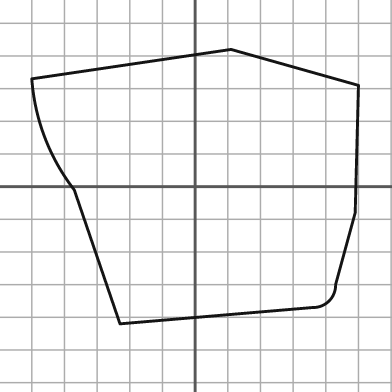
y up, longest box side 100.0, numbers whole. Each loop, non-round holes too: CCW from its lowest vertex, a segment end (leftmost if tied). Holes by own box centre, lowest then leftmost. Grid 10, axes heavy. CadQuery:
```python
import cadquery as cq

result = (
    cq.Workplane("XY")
    .moveTo(-23.0, -42.0)
    .lineTo(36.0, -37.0)
    .threePointArc((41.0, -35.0), (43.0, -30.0))
    .lineTo(49.0, -8.0)
    .lineTo(50.0, 31.0)
    .lineTo(11.0, 42.0)
    .lineTo(-50.0, 33.0)
    .threePointArc((-46.0, 15.0), (-37.0, -1.0))
    .close()
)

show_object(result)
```